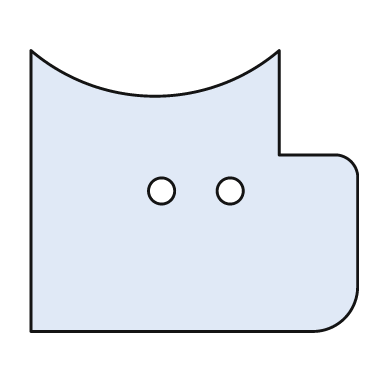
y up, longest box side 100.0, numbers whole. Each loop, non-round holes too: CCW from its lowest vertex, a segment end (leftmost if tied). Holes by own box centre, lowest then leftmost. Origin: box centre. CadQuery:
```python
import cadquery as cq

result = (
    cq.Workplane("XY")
    .moveTo(-50.0, -43.0)
    .lineTo(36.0, -43.0)
    .threePointArc((46.0, -39.0), (50.0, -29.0))
    .lineTo(50.0, 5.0)
    .threePointArc((48.0, 9.0), (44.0, 11.0))
    .lineTo(26.0, 11.0)
    .lineTo(26.0, 43.0)
    .threePointArc((-12.0, 29.0), (-50.0, 43.0))
    .close()
    .moveTo(-10.0, 0.0)
    .circle(4.0)
    .moveTo(11.0, 0.0)
    .circle(4.0)
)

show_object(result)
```